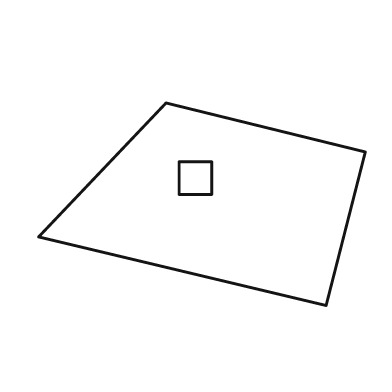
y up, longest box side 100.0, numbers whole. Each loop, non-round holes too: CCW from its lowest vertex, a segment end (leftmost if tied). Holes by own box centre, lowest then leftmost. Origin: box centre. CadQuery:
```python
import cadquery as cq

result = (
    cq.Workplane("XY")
    .moveTo(38.0, -31.0)
    .lineTo(50.0, 16.0)
    .lineTo(-11.0, 31.0)
    .lineTo(-50.0, -10.0)
    .close()
    .moveTo(-7.0, 3.0)
    .lineTo(3.0, 3.0)
    .lineTo(3.0, 13.0)
    .lineTo(-7.0, 13.0)
    .close()
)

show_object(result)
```